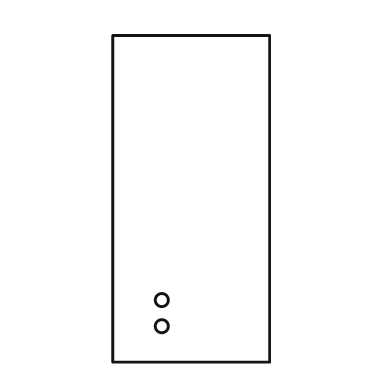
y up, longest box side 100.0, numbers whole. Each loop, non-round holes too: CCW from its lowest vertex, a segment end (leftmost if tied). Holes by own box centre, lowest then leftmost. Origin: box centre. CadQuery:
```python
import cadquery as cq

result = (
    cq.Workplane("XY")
    .moveTo(-24.0, -50.0)
    .lineTo(24.0, -50.0)
    .lineTo(24.0, 50.0)
    .lineTo(-24.0, 50.0)
    .close()
    .moveTo(-9.0, -39.0)
    .circle(2.0)
    .moveTo(-9.0, -31.0)
    .circle(2.0)
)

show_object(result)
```